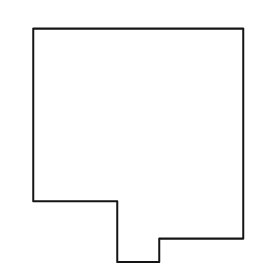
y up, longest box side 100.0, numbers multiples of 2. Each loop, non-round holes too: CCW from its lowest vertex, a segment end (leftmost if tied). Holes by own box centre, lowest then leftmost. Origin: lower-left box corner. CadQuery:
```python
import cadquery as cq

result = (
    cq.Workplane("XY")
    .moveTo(36.0, 0.0)
    .lineTo(54.0, 0.0)
    .lineTo(54.0, 10.0)
    .lineTo(90.0, 10.0)
    .lineTo(90.0, 100.0)
    .lineTo(0.0, 100.0)
    .lineTo(0.0, 26.0)
    .lineTo(36.0, 26.0)
    .close()
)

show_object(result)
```